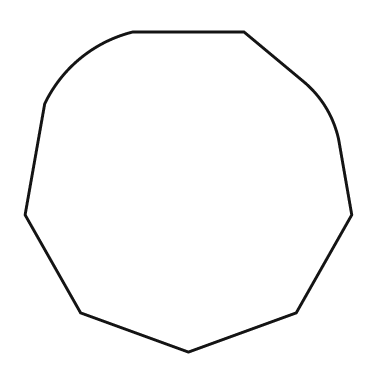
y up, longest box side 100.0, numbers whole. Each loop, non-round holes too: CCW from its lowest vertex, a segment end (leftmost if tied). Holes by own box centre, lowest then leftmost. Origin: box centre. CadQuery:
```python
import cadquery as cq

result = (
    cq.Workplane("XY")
    .moveTo(0.0, -49.0)
    .lineTo(33.0, -37.0)
    .lineTo(50.0, -7.0)
    .lineTo(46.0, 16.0)
    .threePointArc((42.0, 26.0), (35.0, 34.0))
    .lineTo(17.0, 49.0)
    .lineTo(-17.0, 49.0)
    .threePointArc((-33.0, 41.0), (-44.0, 27.0))
    .lineTo(-50.0, -7.0)
    .lineTo(-33.0, -37.0)
    .close()
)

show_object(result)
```